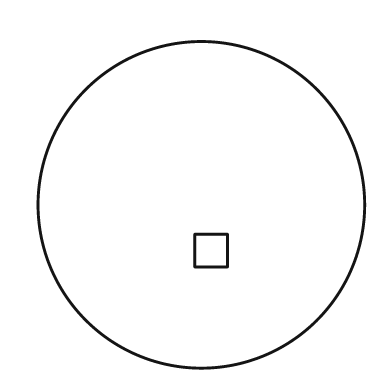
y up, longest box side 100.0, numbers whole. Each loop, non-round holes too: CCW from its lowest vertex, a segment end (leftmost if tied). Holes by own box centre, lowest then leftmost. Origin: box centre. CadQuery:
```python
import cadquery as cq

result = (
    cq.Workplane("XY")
    .moveTo(0.0, 0.0)
    .circle(50.0)
    .moveTo(-2.0, -19.0)
    .lineTo(8.0, -19.0)
    .lineTo(8.0, -9.0)
    .lineTo(-2.0, -9.0)
    .close()
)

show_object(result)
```